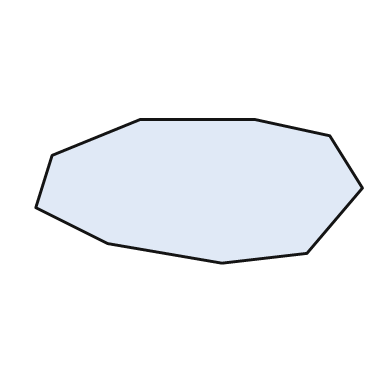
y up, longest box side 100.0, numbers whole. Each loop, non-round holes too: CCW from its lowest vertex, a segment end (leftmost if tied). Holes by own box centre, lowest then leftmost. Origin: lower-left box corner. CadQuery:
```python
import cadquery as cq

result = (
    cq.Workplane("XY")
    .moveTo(57.0, 0.0)
    .lineTo(83.0, 3.0)
    .lineTo(100.0, 23.0)
    .lineTo(90.0, 39.0)
    .lineTo(67.0, 44.0)
    .lineTo(32.0, 44.0)
    .lineTo(5.0, 33.0)
    .lineTo(0.0, 17.0)
    .lineTo(22.0, 6.0)
    .close()
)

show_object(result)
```